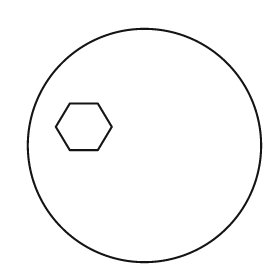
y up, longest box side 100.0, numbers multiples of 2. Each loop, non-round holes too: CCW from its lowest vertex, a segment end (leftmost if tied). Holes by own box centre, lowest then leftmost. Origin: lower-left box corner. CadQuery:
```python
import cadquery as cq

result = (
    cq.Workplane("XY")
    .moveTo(50.0, 50.0)
    .circle(50.0)
    .moveTo(18.0, 48.0)
    .lineTo(30.0, 48.0)
    .lineTo(36.0, 58.0)
    .lineTo(30.0, 68.0)
    .lineTo(18.0, 68.0)
    .lineTo(12.0, 58.0)
    .close()
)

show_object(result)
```